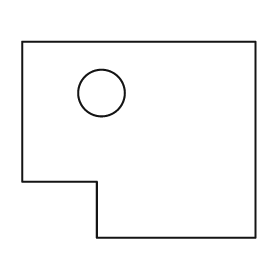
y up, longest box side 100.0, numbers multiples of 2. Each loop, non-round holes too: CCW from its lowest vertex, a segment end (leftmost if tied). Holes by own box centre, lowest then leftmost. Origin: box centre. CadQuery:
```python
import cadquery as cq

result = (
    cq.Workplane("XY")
    .moveTo(-18.0, -42.0)
    .lineTo(50.0, -42.0)
    .lineTo(50.0, 42.0)
    .lineTo(-50.0, 42.0)
    .lineTo(-50.0, -18.0)
    .lineTo(-18.0, -18.0)
    .close()
    .moveTo(-16.0, 20.0)
    .circle(10.0)
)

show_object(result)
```